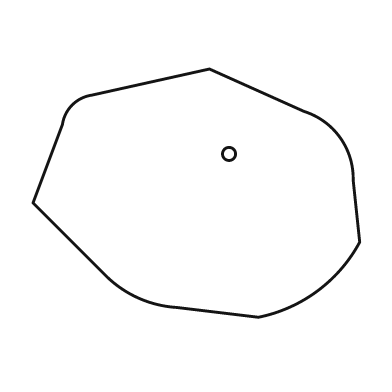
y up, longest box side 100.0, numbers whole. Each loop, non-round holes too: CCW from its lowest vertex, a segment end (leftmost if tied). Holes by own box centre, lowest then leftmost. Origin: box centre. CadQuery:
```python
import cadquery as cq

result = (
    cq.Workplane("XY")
    .moveTo(19.0, -38.0)
    .threePointArc((37.0, -30.0), (50.0, -15.0))
    .lineTo(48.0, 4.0)
    .threePointArc((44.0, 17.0), (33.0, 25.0))
    .lineTo(4.0, 38.0)
    .lineTo(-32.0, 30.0)
    .threePointArc((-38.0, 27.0), (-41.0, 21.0))
    .lineTo(-50.0, -3.0)
    .lineTo(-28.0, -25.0)
    .threePointArc((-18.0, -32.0), (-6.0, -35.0))
    .close()
    .moveTo(10.0, 12.0)
    .circle(2.0)
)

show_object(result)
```